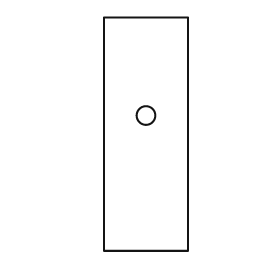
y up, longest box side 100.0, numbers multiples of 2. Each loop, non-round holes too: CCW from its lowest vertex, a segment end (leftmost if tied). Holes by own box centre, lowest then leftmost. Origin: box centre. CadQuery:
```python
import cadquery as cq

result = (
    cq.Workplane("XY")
    .moveTo(-18.0, -50.0)
    .lineTo(18.0, -50.0)
    .lineTo(18.0, 50.0)
    .lineTo(-18.0, 50.0)
    .close()
    .moveTo(0.0, 8.0)
    .circle(4.0)
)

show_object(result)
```